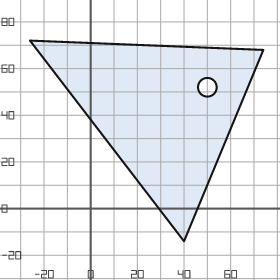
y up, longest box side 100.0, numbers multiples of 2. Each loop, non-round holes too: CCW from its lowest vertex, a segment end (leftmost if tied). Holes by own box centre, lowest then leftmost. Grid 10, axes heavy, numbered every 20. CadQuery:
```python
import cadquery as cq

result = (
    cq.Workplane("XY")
    .moveTo(40.0, -14.0)
    .lineTo(74.0, 68.0)
    .lineTo(-26.0, 72.0)
    .close()
    .moveTo(50.0, 52.0)
    .circle(4.0)
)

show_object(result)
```